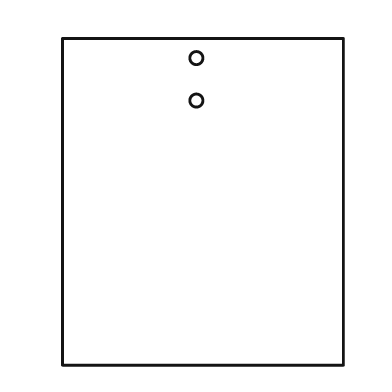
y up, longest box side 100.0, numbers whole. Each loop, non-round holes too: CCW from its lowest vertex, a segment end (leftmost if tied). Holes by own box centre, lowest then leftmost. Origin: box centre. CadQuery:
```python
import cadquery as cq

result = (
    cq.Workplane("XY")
    .moveTo(-43.0, -50.0)
    .lineTo(43.0, -50.0)
    .lineTo(43.0, 50.0)
    .lineTo(-43.0, 50.0)
    .close()
    .moveTo(-2.0, 31.0)
    .circle(2.0)
    .moveTo(-2.0, 44.0)
    .circle(2.0)
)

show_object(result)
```